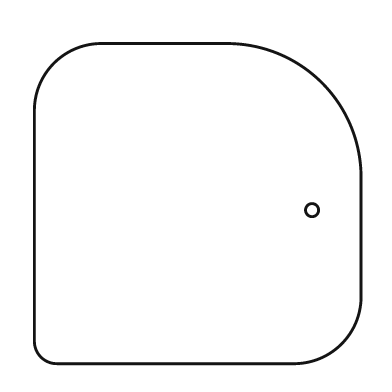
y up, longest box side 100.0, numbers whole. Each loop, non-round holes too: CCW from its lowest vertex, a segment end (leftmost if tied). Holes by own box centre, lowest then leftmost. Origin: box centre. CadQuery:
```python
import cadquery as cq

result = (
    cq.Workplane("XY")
    .moveTo(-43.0, -49.0)
    .lineTo(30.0, -49.0)
    .threePointArc((44.0, -43.0), (50.0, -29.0))
    .lineTo(50.0, 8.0)
    .threePointArc((38.0, 37.0), (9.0, 49.0))
    .lineTo(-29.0, 49.0)
    .threePointArc((-44.0, 43.0), (-50.0, 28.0))
    .lineTo(-50.0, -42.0)
    .threePointArc((-48.0, -47.0), (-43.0, -49.0))
    .close()
    .moveTo(35.0, -2.0)
    .circle(2.0)
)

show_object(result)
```